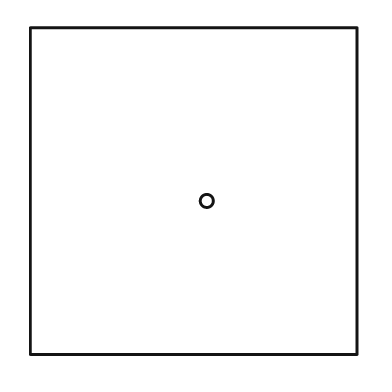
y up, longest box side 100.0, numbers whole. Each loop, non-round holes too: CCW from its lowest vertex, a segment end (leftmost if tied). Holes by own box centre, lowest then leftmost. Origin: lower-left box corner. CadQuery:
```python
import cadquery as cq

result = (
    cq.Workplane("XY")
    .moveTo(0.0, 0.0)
    .lineTo(100.0, 0.0)
    .lineTo(100.0, 100.0)
    .lineTo(0.0, 100.0)
    .close()
    .moveTo(54.0, 47.0)
    .circle(2.0)
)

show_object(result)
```